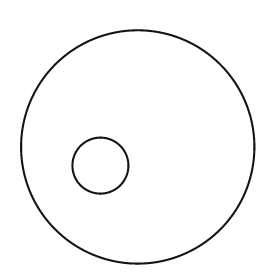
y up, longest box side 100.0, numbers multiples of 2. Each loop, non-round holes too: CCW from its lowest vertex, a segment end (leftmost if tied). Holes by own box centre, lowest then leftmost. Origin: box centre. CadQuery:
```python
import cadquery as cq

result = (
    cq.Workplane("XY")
    .moveTo(0.0, 0.0)
    .circle(50.0)
    .moveTo(-16.0, -8.0)
    .circle(12.0)
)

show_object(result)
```